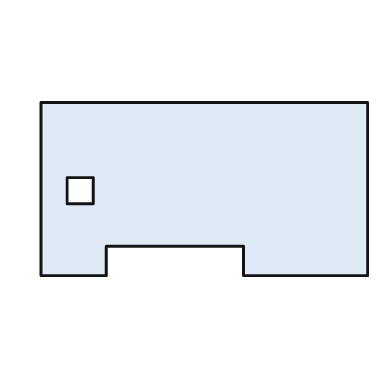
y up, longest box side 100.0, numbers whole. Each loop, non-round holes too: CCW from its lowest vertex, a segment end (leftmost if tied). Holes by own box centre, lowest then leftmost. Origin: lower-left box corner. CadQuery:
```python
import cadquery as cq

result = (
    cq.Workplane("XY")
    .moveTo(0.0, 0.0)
    .lineTo(20.0, 0.0)
    .lineTo(20.0, 9.0)
    .lineTo(62.0, 9.0)
    .lineTo(62.0, 0.0)
    .lineTo(100.0, 0.0)
    .lineTo(100.0, 53.0)
    .lineTo(0.0, 53.0)
    .close()
    .moveTo(8.0, 22.0)
    .lineTo(16.0, 22.0)
    .lineTo(16.0, 30.0)
    .lineTo(8.0, 30.0)
    .close()
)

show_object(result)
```